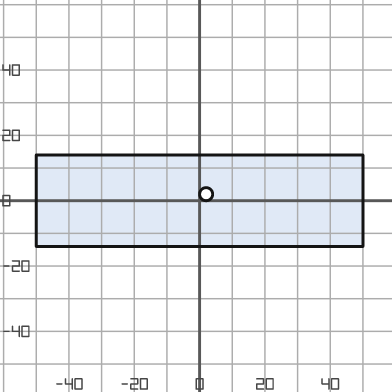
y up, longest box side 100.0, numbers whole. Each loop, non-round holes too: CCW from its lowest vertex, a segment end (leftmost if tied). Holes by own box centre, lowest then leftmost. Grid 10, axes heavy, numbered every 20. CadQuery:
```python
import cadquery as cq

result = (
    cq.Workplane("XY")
    .moveTo(-50.0, -14.0)
    .lineTo(50.0, -14.0)
    .lineTo(50.0, 14.0)
    .lineTo(-50.0, 14.0)
    .close()
    .moveTo(2.0, 2.0)
    .circle(2.0)
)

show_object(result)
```